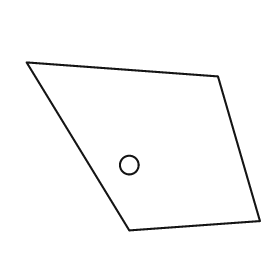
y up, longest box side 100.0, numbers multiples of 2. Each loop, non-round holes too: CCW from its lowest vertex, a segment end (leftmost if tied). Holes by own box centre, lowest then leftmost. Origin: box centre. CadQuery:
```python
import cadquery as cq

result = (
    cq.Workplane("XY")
    .moveTo(-6.0, -36.0)
    .lineTo(50.0, -32.0)
    .lineTo(32.0, 30.0)
    .lineTo(-50.0, 36.0)
    .close()
    .moveTo(-6.0, -8.0)
    .circle(4.0)
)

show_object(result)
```